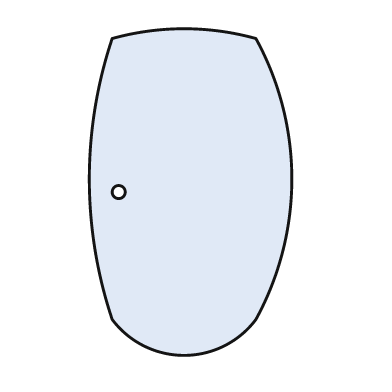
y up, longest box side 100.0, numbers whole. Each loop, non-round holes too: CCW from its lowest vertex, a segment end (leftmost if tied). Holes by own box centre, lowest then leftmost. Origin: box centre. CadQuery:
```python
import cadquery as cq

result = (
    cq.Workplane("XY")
    .moveTo(-24.0, -39.0)
    .threePointArc((-2.0, -50.0), (20.0, -39.0))
    .threePointArc((31.0, 4.0), (20.0, 47.0))
    .threePointArc((-2.0, 50.0), (-24.0, 47.0))
    .threePointArc((-31.0, 4.0), (-24.0, -39.0))
    .close()
    .moveTo(-22.0, 0.0)
    .circle(2.0)
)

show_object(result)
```